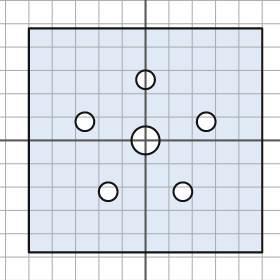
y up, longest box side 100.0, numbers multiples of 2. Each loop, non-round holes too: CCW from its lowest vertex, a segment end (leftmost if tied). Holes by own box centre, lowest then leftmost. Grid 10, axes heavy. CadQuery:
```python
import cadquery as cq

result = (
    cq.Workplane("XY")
    .moveTo(-50.0, -48.0)
    .lineTo(50.0, -48.0)
    .lineTo(50.0, 48.0)
    .lineTo(-50.0, 48.0)
    .close()
    .moveTo(-16.0, -22.0)
    .circle(4.0)
    .moveTo(16.0, -22.0)
    .circle(4.0)
    .moveTo(0.0, 0.0)
    .circle(6.0)
    .moveTo(-26.0, 8.0)
    .circle(4.0)
    .moveTo(26.0, 8.0)
    .circle(4.0)
    .moveTo(0.0, 26.0)
    .circle(4.0)
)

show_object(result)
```